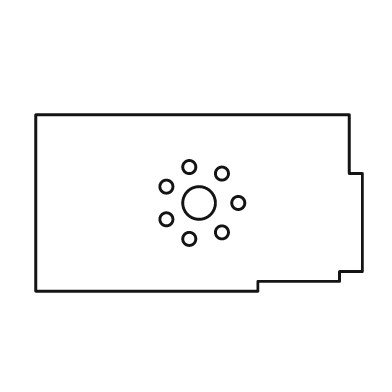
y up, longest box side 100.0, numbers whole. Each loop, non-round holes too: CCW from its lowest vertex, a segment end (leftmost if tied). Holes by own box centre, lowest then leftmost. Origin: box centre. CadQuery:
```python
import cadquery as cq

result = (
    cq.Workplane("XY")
    .moveTo(-50.0, -27.0)
    .lineTo(18.0, -27.0)
    .lineTo(18.0, -24.0)
    .lineTo(43.0, -24.0)
    .lineTo(43.0, -21.0)
    .lineTo(50.0, -21.0)
    .lineTo(50.0, 9.0)
    .lineTo(46.0, 9.0)
    .lineTo(46.0, 27.0)
    .lineTo(-50.0, 27.0)
    .close()
    .moveTo(-3.0, -11.0)
    .circle(2.0)
    .moveTo(7.0, -9.0)
    .circle(2.0)
    .moveTo(-10.0, -5.0)
    .circle(2.0)
    .moveTo(0.0, 0.0)
    .circle(5.0)
    .moveTo(12.0, 0.0)
    .circle(2.0)
    .moveTo(-10.0, 5.0)
    .circle(2.0)
    .moveTo(7.0, 9.0)
    .circle(2.0)
    .moveTo(-3.0, 11.0)
    .circle(2.0)
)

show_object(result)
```